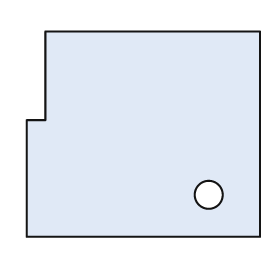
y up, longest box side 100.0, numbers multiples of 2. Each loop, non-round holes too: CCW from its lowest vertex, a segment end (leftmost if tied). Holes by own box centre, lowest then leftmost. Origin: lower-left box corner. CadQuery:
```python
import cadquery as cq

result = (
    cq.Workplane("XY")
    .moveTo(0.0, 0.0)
    .lineTo(100.0, 0.0)
    .lineTo(100.0, 88.0)
    .lineTo(8.0, 88.0)
    .lineTo(8.0, 50.0)
    .lineTo(0.0, 50.0)
    .close()
    .moveTo(78.0, 18.0)
    .circle(6.0)
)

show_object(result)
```